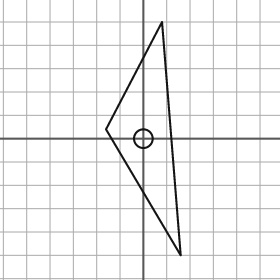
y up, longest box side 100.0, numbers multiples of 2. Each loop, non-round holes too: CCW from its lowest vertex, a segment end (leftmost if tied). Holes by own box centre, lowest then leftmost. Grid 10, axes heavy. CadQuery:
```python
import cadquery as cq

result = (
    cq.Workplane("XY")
    .moveTo(16.0, -50.0)
    .lineTo(8.0, 50.0)
    .lineTo(-16.0, 4.0)
    .close()
    .moveTo(0.0, 0.0)
    .circle(4.0)
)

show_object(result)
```